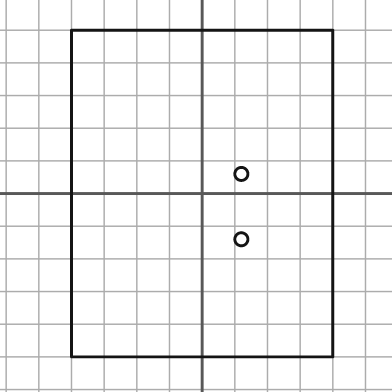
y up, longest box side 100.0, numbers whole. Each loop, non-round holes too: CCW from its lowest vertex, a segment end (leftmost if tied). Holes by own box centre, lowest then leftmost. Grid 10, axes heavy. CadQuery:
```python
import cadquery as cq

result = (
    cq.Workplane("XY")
    .moveTo(-40.0, -50.0)
    .lineTo(40.0, -50.0)
    .lineTo(40.0, 50.0)
    .lineTo(-40.0, 50.0)
    .close()
    .moveTo(12.0, -14.0)
    .circle(2.0)
    .moveTo(12.0, 6.0)
    .circle(2.0)
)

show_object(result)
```